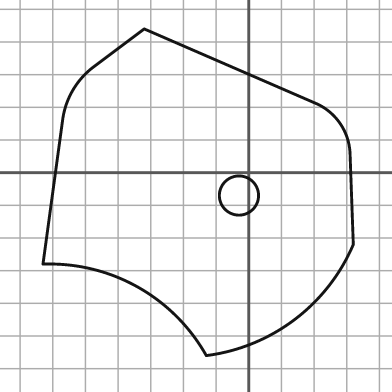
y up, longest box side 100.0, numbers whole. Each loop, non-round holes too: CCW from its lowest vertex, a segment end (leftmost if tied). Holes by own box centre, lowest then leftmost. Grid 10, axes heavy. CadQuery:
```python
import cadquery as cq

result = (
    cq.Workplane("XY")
    .moveTo(-13.0, -56.0)
    .threePointArc((14.0, -45.0), (32.0, -22.0))
    .lineTo(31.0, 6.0)
    .threePointArc((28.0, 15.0), (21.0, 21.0))
    .lineTo(-32.0, 44.0)
    .lineTo(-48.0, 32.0)
    .threePointArc((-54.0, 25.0), (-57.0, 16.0))
    .lineTo(-63.0, -28.0)
    .threePointArc((-34.0, -35.0), (-13.0, -56.0))
    .close()
    .moveTo(-3.0, -7.0)
    .circle(6.0)
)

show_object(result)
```